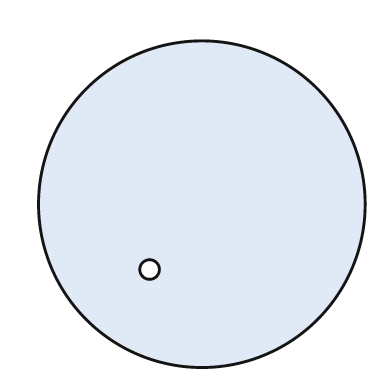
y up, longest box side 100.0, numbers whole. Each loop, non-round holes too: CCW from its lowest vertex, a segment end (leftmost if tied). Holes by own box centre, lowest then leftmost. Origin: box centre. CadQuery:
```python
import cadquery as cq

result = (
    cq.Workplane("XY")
    .moveTo(0.0, 0.0)
    .circle(50.0)
    .moveTo(-16.0, -20.0)
    .circle(3.0)
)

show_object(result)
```